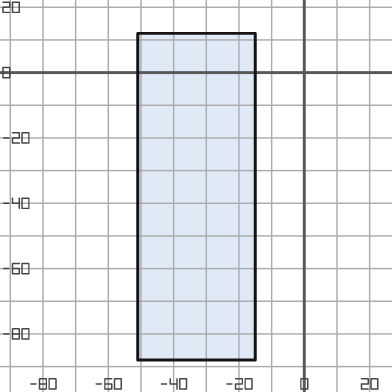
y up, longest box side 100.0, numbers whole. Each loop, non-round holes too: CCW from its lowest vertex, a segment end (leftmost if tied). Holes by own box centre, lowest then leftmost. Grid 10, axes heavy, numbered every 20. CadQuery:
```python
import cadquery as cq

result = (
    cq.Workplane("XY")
    .moveTo(-51.0, -88.0)
    .lineTo(-15.0, -88.0)
    .lineTo(-15.0, 12.0)
    .lineTo(-51.0, 12.0)
    .close()
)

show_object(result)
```